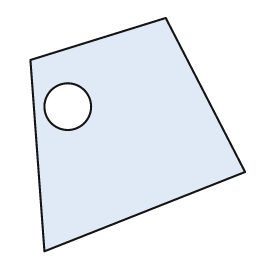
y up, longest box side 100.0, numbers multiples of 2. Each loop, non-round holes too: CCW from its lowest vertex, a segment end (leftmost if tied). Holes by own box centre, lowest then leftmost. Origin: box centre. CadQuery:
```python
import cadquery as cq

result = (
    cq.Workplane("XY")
    .moveTo(-40.0, -50.0)
    .lineTo(46.0, -16.0)
    .lineTo(12.0, 50.0)
    .lineTo(-46.0, 32.0)
    .close()
    .moveTo(-30.0, 12.0)
    .circle(10.0)
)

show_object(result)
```